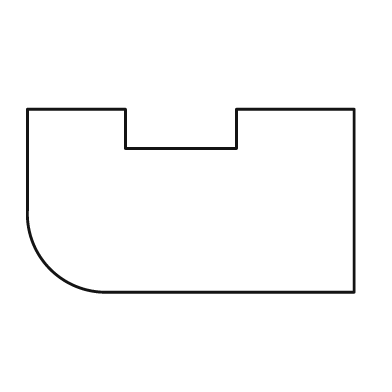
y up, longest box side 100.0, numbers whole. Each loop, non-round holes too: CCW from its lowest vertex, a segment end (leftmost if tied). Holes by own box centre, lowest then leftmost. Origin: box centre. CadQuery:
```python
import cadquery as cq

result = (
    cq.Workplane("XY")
    .moveTo(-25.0, -28.0)
    .lineTo(50.0, -28.0)
    .lineTo(50.0, 28.0)
    .lineTo(14.0, 28.0)
    .lineTo(14.0, 16.0)
    .lineTo(-20.0, 16.0)
    .lineTo(-20.0, 28.0)
    .lineTo(-50.0, 28.0)
    .lineTo(-50.0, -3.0)
    .threePointArc((-43.0, -21.0), (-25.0, -28.0))
    .close()
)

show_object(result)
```